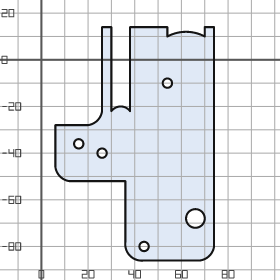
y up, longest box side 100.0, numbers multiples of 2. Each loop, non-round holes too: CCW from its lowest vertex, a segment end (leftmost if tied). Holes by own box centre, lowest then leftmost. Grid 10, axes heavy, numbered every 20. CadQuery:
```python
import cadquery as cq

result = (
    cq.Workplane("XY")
    .moveTo(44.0, -86.0)
    .lineTo(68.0, -86.0)
    .threePointArc((72.0, -84.0), (74.0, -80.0))
    .lineTo(74.0, 14.0)
    .lineTo(70.0, 14.0)
    .lineTo(70.0, 10.0)
    .threePointArc((62.0, 12.0), (54.0, 10.0))
    .lineTo(54.0, 14.0)
    .lineTo(38.0, 14.0)
    .lineTo(38.0, -22.0)
    .threePointArc((34.0, -20.0), (30.0, -22.0))
    .lineTo(30.0, 14.0)
    .lineTo(26.0, 14.0)
    .lineTo(26.0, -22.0)
    .threePointArc((24.0, -26.0), (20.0, -28.0))
    .lineTo(6.0, -28.0)
    .lineTo(6.0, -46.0)
    .threePointArc((8.0, -50.0), (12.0, -52.0))
    .lineTo(36.0, -52.0)
    .lineTo(36.0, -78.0)
    .threePointArc((38.0, -84.0), (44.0, -86.0))
    .close()
    .moveTo(44.0, -80.0)
    .circle(2.0)
    .moveTo(66.0, -68.0)
    .circle(4.0)
    .moveTo(26.0, -40.0)
    .circle(2.0)
    .moveTo(16.0, -36.0)
    .circle(2.0)
    .moveTo(54.0, -10.0)
    .circle(2.0)
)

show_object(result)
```